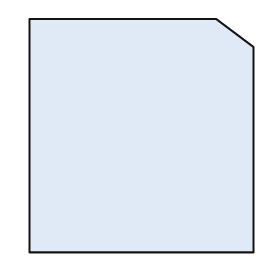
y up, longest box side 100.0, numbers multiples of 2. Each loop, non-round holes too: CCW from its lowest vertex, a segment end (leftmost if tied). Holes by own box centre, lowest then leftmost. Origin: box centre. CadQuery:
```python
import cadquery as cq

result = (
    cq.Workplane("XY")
    .moveTo(-48.0, -50.0)
    .lineTo(48.0, -50.0)
    .lineTo(48.0, 38.0)
    .lineTo(32.0, 50.0)
    .lineTo(-48.0, 50.0)
    .close()
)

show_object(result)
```